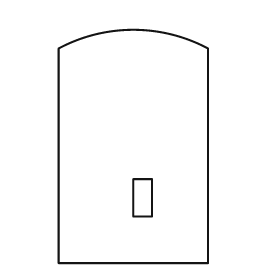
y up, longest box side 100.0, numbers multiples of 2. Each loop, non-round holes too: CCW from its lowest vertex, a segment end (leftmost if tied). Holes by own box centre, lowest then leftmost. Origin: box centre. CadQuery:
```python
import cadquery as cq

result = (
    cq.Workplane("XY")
    .moveTo(-32.0, -50.0)
    .lineTo(32.0, -50.0)
    .lineTo(32.0, 42.0)
    .threePointArc((0.0, 50.0), (-32.0, 42.0))
    .close()
    .moveTo(0.0, -30.0)
    .lineTo(8.0, -30.0)
    .lineTo(8.0, -14.0)
    .lineTo(0.0, -14.0)
    .close()
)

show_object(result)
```